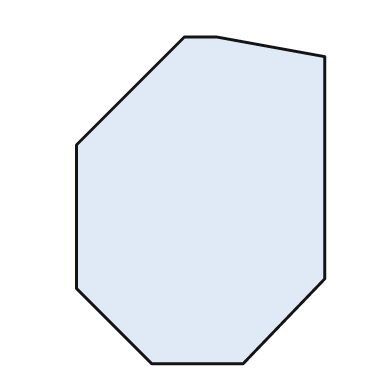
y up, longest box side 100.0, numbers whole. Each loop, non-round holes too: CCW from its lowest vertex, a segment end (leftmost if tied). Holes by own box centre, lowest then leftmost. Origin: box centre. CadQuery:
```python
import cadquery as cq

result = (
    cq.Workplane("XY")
    .moveTo(-15.0, -50.0)
    .lineTo(13.0, -50.0)
    .lineTo(38.0, -24.0)
    .lineTo(38.0, 44.0)
    .lineTo(5.0, 50.0)
    .lineTo(-5.0, 50.0)
    .lineTo(-38.0, 17.0)
    .lineTo(-38.0, -27.0)
    .close()
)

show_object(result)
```